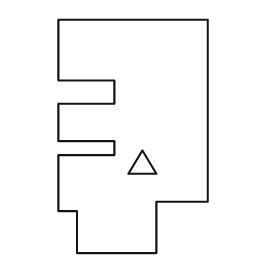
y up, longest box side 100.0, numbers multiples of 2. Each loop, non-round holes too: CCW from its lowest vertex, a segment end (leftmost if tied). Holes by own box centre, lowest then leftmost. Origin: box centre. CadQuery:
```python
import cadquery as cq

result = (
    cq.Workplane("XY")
    .moveTo(-24.0, -50.0)
    .lineTo(10.0, -50.0)
    .lineTo(10.0, -28.0)
    .lineTo(32.0, -28.0)
    .lineTo(32.0, 50.0)
    .lineTo(-32.0, 50.0)
    .lineTo(-32.0, 24.0)
    .lineTo(-8.0, 24.0)
    .lineTo(-8.0, 14.0)
    .lineTo(-32.0, 14.0)
    .lineTo(-32.0, -2.0)
    .lineTo(-8.0, -2.0)
    .lineTo(-8.0, -8.0)
    .lineTo(-32.0, -8.0)
    .lineTo(-32.0, -32.0)
    .lineTo(-24.0, -32.0)
    .close()
    .moveTo(-2.0, -16.0)
    .lineTo(10.0, -16.0)
    .lineTo(4.0, -6.0)
    .close()
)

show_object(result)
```